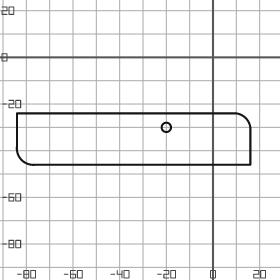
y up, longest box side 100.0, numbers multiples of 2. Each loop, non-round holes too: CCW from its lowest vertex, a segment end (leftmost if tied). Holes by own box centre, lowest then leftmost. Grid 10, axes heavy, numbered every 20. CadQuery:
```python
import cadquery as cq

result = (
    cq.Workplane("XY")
    .moveTo(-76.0, -46.0)
    .lineTo(16.0, -46.0)
    .lineTo(16.0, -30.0)
    .threePointArc((14.0, -26.0), (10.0, -24.0))
    .lineTo(-84.0, -24.0)
    .lineTo(-84.0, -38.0)
    .threePointArc((-82.0, -44.0), (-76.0, -46.0))
    .close()
    .moveTo(-20.0, -30.0)
    .circle(2.0)
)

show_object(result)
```